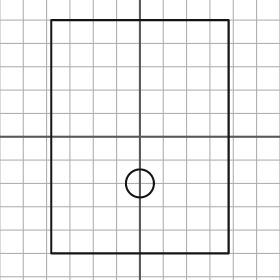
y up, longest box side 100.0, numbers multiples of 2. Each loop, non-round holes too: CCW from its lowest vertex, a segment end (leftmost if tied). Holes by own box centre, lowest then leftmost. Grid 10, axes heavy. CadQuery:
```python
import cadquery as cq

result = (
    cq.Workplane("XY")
    .moveTo(-38.0, -50.0)
    .lineTo(38.0, -50.0)
    .lineTo(38.0, 50.0)
    .lineTo(-38.0, 50.0)
    .close()
    .moveTo(0.0, -20.0)
    .circle(6.0)
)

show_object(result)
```